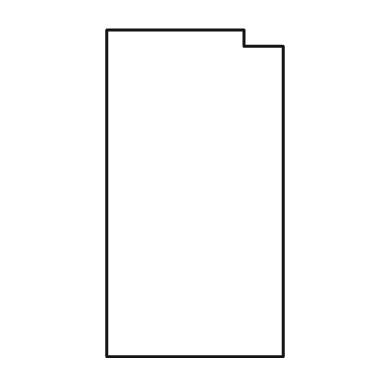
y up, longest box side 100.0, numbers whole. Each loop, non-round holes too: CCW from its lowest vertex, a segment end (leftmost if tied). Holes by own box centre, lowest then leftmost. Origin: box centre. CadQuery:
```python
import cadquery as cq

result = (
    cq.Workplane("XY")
    .moveTo(-27.0, -50.0)
    .lineTo(27.0, -50.0)
    .lineTo(27.0, 45.0)
    .lineTo(15.0, 45.0)
    .lineTo(15.0, 50.0)
    .lineTo(-27.0, 50.0)
    .close()
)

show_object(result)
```